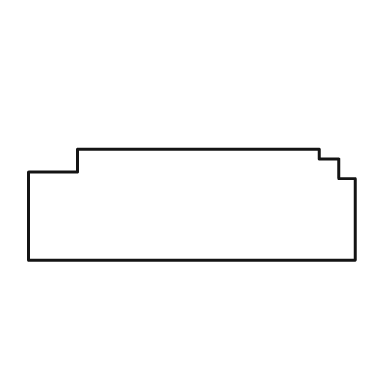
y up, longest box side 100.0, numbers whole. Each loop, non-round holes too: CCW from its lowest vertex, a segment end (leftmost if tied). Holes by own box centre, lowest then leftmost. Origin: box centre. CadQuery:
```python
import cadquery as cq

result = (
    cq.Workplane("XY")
    .moveTo(-50.0, -17.0)
    .lineTo(50.0, -17.0)
    .lineTo(50.0, 8.0)
    .lineTo(45.0, 8.0)
    .lineTo(45.0, 14.0)
    .lineTo(39.0, 14.0)
    .lineTo(39.0, 17.0)
    .lineTo(-35.0, 17.0)
    .lineTo(-35.0, 10.0)
    .lineTo(-50.0, 10.0)
    .close()
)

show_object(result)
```